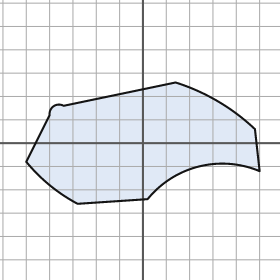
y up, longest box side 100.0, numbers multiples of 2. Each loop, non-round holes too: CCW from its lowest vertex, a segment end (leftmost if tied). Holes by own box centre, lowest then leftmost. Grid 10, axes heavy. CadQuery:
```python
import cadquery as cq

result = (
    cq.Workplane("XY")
    .moveTo(-28.0, -26.0)
    .lineTo(2.0, -24.0)
    .threePointArc((24.0, -10.0), (50.0, -12.0))
    .lineTo(48.0, 6.0)
    .threePointArc((32.0, 18.0), (14.0, 26.0))
    .lineTo(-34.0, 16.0)
    .threePointArc((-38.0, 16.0), (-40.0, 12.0))
    .lineTo(-50.0, -8.0)
    .threePointArc((-40.0, -18.0), (-28.0, -26.0))
    .close()
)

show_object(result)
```